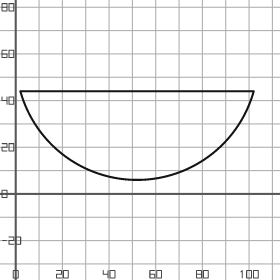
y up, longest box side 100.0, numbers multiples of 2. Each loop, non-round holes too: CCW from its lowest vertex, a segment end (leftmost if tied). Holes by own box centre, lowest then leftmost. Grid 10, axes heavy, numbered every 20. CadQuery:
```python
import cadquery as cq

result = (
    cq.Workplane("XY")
    .moveTo(2.0, 44.0)
    .threePointArc((52.0, 6.0), (102.0, 44.0))
    .close()
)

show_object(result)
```